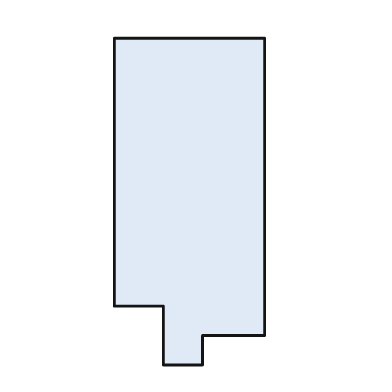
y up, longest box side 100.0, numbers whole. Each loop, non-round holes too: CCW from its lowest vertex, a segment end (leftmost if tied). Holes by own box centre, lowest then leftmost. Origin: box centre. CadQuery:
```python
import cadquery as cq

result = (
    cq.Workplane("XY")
    .moveTo(-8.0, -50.0)
    .lineTo(4.0, -50.0)
    .lineTo(4.0, -41.0)
    .lineTo(23.0, -41.0)
    .lineTo(23.0, 50.0)
    .lineTo(-23.0, 50.0)
    .lineTo(-23.0, -32.0)
    .lineTo(-8.0, -32.0)
    .close()
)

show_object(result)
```